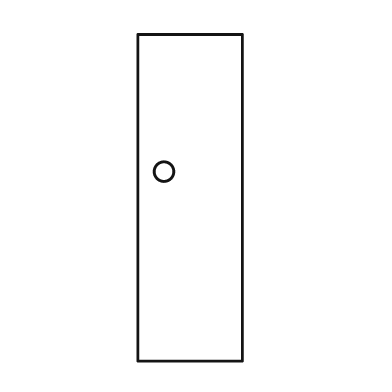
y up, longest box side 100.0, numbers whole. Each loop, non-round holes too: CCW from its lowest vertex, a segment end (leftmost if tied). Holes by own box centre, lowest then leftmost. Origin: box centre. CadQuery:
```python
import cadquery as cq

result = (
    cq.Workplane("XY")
    .moveTo(-16.0, -50.0)
    .lineTo(16.0, -50.0)
    .lineTo(16.0, 50.0)
    .lineTo(-16.0, 50.0)
    .close()
    .moveTo(-8.0, 8.0)
    .circle(3.0)
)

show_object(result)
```